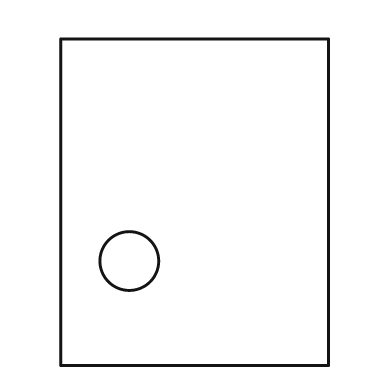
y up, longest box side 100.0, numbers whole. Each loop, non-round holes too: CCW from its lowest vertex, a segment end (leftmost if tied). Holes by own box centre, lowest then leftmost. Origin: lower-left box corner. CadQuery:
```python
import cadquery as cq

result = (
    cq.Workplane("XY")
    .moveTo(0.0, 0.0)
    .lineTo(82.0, 0.0)
    .lineTo(82.0, 100.0)
    .lineTo(0.0, 100.0)
    .close()
    .moveTo(21.0, 32.0)
    .circle(9.0)
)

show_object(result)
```